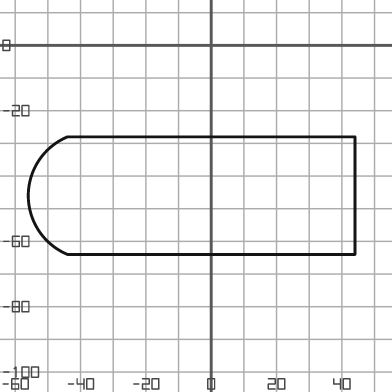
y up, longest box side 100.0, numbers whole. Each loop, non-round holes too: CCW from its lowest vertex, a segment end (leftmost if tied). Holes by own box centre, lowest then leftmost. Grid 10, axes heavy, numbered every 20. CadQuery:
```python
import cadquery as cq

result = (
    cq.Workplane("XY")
    .moveTo(-44.0, -64.0)
    .lineTo(44.0, -64.0)
    .lineTo(44.0, -28.0)
    .lineTo(-44.0, -28.0)
    .threePointArc((-56.0, -46.0), (-44.0, -64.0))
    .close()
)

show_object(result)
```